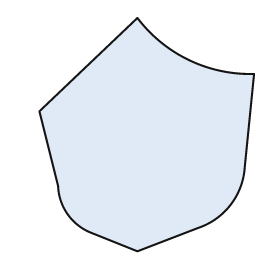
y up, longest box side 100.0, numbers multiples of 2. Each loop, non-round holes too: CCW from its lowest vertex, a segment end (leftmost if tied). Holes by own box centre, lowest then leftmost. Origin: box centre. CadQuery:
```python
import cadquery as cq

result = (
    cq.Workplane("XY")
    .moveTo(-4.0, -50.0)
    .lineTo(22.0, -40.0)
    .threePointArc((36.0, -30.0), (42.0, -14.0))
    .lineTo(46.0, 26.0)
    .threePointArc((18.0, 32.0), (-4.0, 50.0))
    .lineTo(-46.0, 10.0)
    .lineTo(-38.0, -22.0)
    .threePointArc((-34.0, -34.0), (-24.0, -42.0))
    .close()
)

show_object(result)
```